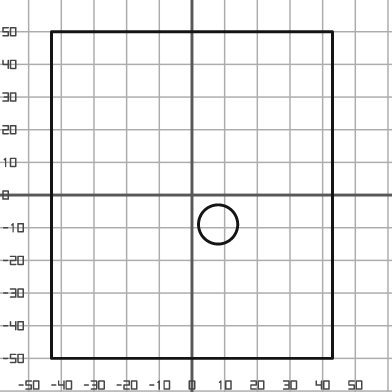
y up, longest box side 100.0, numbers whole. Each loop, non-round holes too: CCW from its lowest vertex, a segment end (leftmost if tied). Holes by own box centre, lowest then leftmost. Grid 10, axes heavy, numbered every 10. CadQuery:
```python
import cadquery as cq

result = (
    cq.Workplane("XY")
    .moveTo(-43.0, -50.0)
    .lineTo(43.0, -50.0)
    .lineTo(43.0, 50.0)
    .lineTo(-43.0, 50.0)
    .close()
    .moveTo(8.0, -9.0)
    .circle(6.0)
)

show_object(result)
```